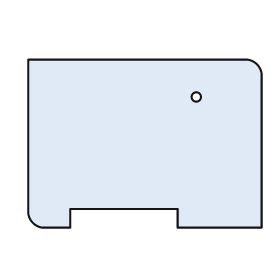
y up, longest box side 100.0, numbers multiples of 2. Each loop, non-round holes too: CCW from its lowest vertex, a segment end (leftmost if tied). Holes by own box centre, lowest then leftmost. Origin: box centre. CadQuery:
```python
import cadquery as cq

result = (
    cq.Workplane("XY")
    .moveTo(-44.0, -36.0)
    .lineTo(-32.0, -36.0)
    .lineTo(-32.0, -28.0)
    .lineTo(14.0, -28.0)
    .lineTo(14.0, -36.0)
    .lineTo(50.0, -36.0)
    .lineTo(50.0, 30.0)
    .threePointArc((48.0, 34.0), (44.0, 36.0))
    .lineTo(-50.0, 36.0)
    .lineTo(-50.0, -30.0)
    .threePointArc((-48.0, -34.0), (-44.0, -36.0))
    .close()
    .moveTo(22.0, 20.0)
    .circle(2.0)
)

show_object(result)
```